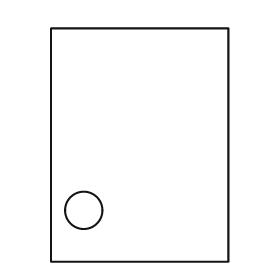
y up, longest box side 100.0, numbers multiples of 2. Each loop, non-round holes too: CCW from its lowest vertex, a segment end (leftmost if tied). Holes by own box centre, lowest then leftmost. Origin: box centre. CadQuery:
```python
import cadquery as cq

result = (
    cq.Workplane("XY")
    .moveTo(-38.0, -50.0)
    .lineTo(38.0, -50.0)
    .lineTo(38.0, 50.0)
    .lineTo(-38.0, 50.0)
    .close()
    .moveTo(-24.0, -28.0)
    .circle(8.0)
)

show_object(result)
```